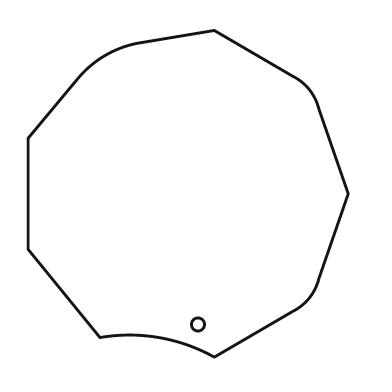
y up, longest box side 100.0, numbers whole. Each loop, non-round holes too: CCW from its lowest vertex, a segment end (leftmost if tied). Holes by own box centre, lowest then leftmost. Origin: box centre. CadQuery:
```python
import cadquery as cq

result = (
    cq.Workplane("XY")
    .moveTo(8.0, -50.0)
    .lineTo(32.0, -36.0)
    .threePointArc((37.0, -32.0), (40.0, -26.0))
    .lineTo(49.0, 0.0)
    .lineTo(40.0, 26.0)
    .threePointArc((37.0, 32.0), (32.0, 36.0))
    .lineTo(8.0, 50.0)
    .lineTo(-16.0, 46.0)
    .threePointArc((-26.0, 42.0), (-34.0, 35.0))
    .lineTo(-49.0, 17.0)
    .lineTo(-49.0, -17.0)
    .lineTo(-27.0, -44.0)
    .threePointArc((-9.0, -44.0), (8.0, -50.0))
    .close()
    .moveTo(3.0, -40.0)
    .circle(2.0)
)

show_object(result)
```